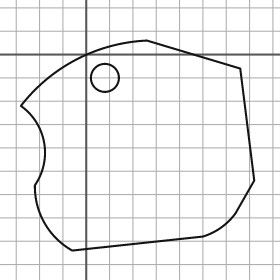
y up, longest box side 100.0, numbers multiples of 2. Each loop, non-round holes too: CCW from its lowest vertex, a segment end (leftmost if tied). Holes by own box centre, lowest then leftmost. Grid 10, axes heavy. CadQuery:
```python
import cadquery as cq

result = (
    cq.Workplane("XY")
    .moveTo(-6.0, -84.0)
    .lineTo(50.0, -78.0)
    .threePointArc((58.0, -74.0), (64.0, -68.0))
    .lineTo(72.0, -54.0)
    .lineTo(66.0, -6.0)
    .lineTo(26.0, 6.0)
    .threePointArc((-4.0, -2.0), (-28.0, -22.0))
    .threePointArc((-18.0, -38.0), (-22.0, -56.0))
    .threePointArc((-18.0, -72.0), (-6.0, -84.0))
    .close()
    .moveTo(8.0, -10.0)
    .circle(6.0)
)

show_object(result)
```